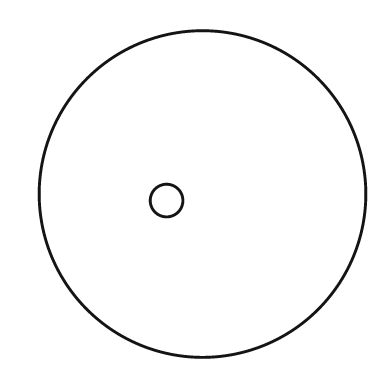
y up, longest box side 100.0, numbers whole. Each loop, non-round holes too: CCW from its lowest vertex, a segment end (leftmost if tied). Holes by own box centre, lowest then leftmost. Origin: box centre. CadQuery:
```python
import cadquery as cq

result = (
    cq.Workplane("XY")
    .moveTo(0.0, 0.0)
    .circle(50.0)
    .moveTo(-11.0, -2.0)
    .circle(5.0)
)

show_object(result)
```